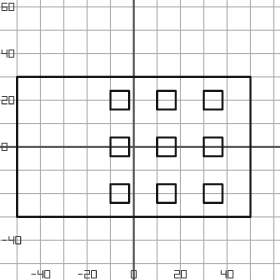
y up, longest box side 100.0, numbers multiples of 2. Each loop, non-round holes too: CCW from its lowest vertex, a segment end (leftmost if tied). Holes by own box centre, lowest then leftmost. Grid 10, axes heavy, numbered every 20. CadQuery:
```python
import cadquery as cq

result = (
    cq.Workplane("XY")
    .moveTo(-50.0, -30.0)
    .lineTo(50.0, -30.0)
    .lineTo(50.0, 30.0)
    .lineTo(-50.0, 30.0)
    .close()
    .moveTo(-10.0, -24.0)
    .lineTo(-2.0, -24.0)
    .lineTo(-2.0, -16.0)
    .lineTo(-10.0, -16.0)
    .close()
    .moveTo(10.0, -24.0)
    .lineTo(18.0, -24.0)
    .lineTo(18.0, -16.0)
    .lineTo(10.0, -16.0)
    .close()
    .moveTo(30.0, -24.0)
    .lineTo(38.0, -24.0)
    .lineTo(38.0, -16.0)
    .lineTo(30.0, -16.0)
    .close()
    .moveTo(-10.0, -4.0)
    .lineTo(-2.0, -4.0)
    .lineTo(-2.0, 4.0)
    .lineTo(-10.0, 4.0)
    .close()
    .moveTo(10.0, -4.0)
    .lineTo(18.0, -4.0)
    .lineTo(18.0, 4.0)
    .lineTo(10.0, 4.0)
    .close()
    .moveTo(30.0, -4.0)
    .lineTo(38.0, -4.0)
    .lineTo(38.0, 4.0)
    .lineTo(30.0, 4.0)
    .close()
    .moveTo(-10.0, 16.0)
    .lineTo(-2.0, 16.0)
    .lineTo(-2.0, 24.0)
    .lineTo(-10.0, 24.0)
    .close()
    .moveTo(10.0, 16.0)
    .lineTo(18.0, 16.0)
    .lineTo(18.0, 24.0)
    .lineTo(10.0, 24.0)
    .close()
    .moveTo(30.0, 16.0)
    .lineTo(38.0, 16.0)
    .lineTo(38.0, 24.0)
    .lineTo(30.0, 24.0)
    .close()
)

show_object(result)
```